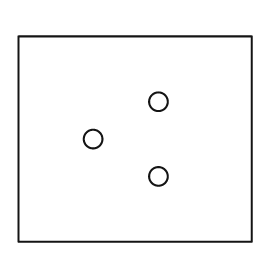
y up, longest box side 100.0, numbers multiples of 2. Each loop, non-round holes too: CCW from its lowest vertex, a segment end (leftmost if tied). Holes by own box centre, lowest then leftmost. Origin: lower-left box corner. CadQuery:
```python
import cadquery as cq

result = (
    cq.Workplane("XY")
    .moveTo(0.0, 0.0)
    .lineTo(100.0, 0.0)
    .lineTo(100.0, 88.0)
    .lineTo(0.0, 88.0)
    .close()
    .moveTo(60.0, 28.0)
    .circle(4.0)
    .moveTo(32.0, 44.0)
    .circle(4.0)
    .moveTo(60.0, 60.0)
    .circle(4.0)
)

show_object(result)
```